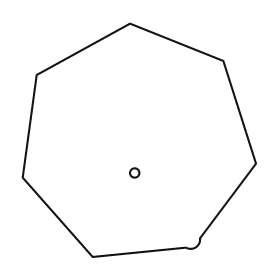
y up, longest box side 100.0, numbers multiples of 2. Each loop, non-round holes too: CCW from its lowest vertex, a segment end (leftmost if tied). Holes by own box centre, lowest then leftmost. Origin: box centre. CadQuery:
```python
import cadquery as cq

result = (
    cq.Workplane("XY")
    .moveTo(-20.0, -50.0)
    .lineTo(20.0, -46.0)
    .threePointArc((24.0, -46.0), (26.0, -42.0))
    .lineTo(50.0, -10.0)
    .lineTo(36.0, 34.0)
    .lineTo(-4.0, 50.0)
    .lineTo(-44.0, 28.0)
    .lineTo(-50.0, -16.0)
    .close()
    .moveTo(-2.0, -14.0)
    .circle(2.0)
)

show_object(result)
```